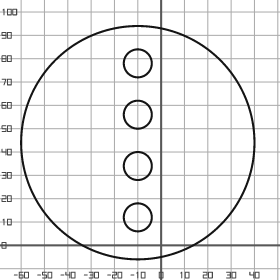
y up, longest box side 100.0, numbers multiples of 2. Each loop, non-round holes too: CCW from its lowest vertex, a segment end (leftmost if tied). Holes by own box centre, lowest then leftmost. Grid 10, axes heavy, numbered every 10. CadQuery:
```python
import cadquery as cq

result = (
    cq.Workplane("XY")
    .moveTo(-10.0, 44.0)
    .circle(50.0)
    .moveTo(-10.0, 12.0)
    .circle(6.0)
    .moveTo(-10.0, 34.0)
    .circle(6.0)
    .moveTo(-10.0, 56.0)
    .circle(6.0)
    .moveTo(-10.0, 78.0)
    .circle(6.0)
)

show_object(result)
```